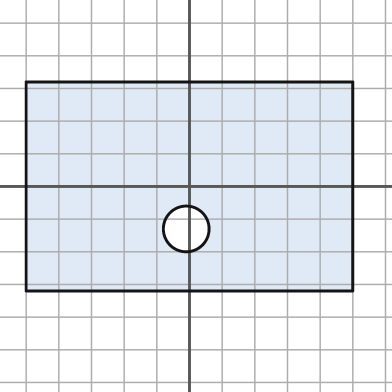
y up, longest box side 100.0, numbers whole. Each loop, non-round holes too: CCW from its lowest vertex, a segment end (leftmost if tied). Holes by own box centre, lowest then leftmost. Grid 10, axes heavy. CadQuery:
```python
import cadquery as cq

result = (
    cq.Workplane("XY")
    .moveTo(-50.0, -32.0)
    .lineTo(50.0, -32.0)
    .lineTo(50.0, 32.0)
    .lineTo(-50.0, 32.0)
    .close()
    .moveTo(-1.0, -13.0)
    .circle(7.0)
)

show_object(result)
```